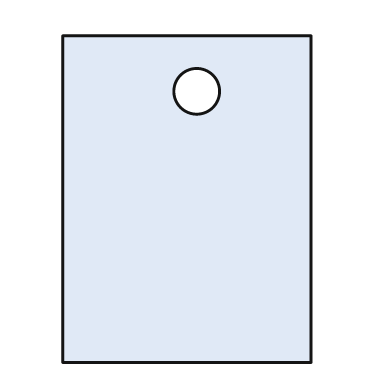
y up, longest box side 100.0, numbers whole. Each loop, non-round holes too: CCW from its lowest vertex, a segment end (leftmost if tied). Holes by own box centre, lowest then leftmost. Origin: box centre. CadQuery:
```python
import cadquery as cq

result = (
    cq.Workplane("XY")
    .moveTo(-38.0, -50.0)
    .lineTo(38.0, -50.0)
    .lineTo(38.0, 50.0)
    .lineTo(-38.0, 50.0)
    .close()
    .moveTo(3.0, 33.0)
    .circle(7.0)
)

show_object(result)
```